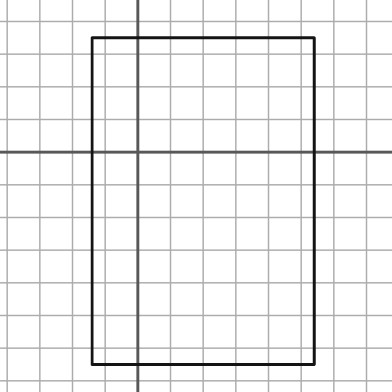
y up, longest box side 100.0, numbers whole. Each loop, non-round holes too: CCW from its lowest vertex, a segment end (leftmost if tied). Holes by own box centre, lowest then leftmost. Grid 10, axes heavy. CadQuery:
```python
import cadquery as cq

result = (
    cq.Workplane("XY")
    .moveTo(-14.0, -65.0)
    .lineTo(54.0, -65.0)
    .lineTo(54.0, 35.0)
    .lineTo(-14.0, 35.0)
    .close()
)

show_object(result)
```